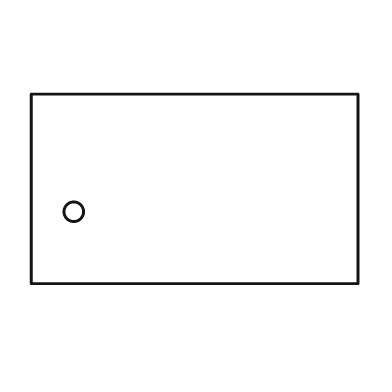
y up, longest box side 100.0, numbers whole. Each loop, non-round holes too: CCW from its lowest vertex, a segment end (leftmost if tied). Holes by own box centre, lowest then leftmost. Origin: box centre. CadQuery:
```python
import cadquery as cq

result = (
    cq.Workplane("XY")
    .moveTo(-50.0, -29.0)
    .lineTo(50.0, -29.0)
    .lineTo(50.0, 29.0)
    .lineTo(-50.0, 29.0)
    .close()
    .moveTo(-37.0, -7.0)
    .circle(3.0)
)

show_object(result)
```